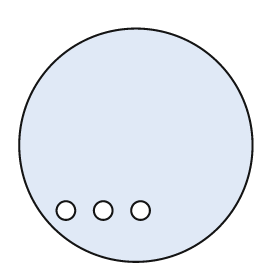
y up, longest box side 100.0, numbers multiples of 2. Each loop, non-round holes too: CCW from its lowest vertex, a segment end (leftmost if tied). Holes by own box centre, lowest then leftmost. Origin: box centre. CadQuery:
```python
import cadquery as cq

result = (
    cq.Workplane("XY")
    .moveTo(0.0, 0.0)
    .circle(50.0)
    .moveTo(-30.0, -28.0)
    .circle(4.0)
    .moveTo(-14.0, -28.0)
    .circle(4.0)
    .moveTo(2.0, -28.0)
    .circle(4.0)
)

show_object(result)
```